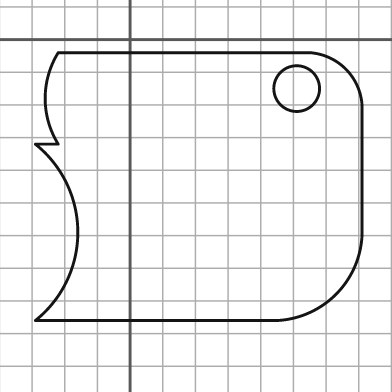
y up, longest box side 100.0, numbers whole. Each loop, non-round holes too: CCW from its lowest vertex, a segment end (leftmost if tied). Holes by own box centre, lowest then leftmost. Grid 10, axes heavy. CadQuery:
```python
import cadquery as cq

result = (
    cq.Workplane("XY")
    .moveTo(-29.0, -86.0)
    .lineTo(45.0, -86.0)
    .threePointArc((63.0, -78.0), (71.0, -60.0))
    .lineTo(71.0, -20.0)
    .threePointArc((66.0, -9.0), (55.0, -4.0))
    .lineTo(-22.0, -4.0)
    .threePointArc((-26.0, -18.0), (-22.0, -32.0))
    .lineTo(-29.0, -32.0)
    .threePointArc((-16.0, -59.0), (-29.0, -86.0))
    .close()
    .moveTo(51.0, -15.0)
    .circle(7.0)
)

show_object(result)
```